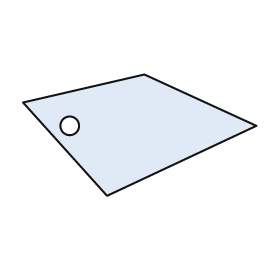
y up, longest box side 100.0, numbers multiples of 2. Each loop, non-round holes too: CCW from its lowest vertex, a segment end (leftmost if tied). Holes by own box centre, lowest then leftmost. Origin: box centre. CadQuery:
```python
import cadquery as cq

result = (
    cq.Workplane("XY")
    .moveTo(-14.0, -26.0)
    .lineTo(50.0, 4.0)
    .lineTo(2.0, 26.0)
    .lineTo(-50.0, 14.0)
    .close()
    .moveTo(-30.0, 4.0)
    .circle(4.0)
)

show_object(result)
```